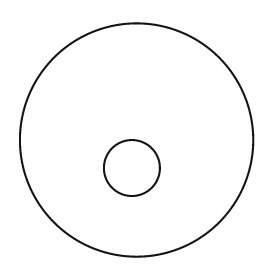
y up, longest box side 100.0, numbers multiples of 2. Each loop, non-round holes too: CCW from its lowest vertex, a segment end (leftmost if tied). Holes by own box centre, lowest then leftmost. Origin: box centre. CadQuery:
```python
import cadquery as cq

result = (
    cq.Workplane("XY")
    .moveTo(0.0, 0.0)
    .circle(50.0)
    .moveTo(-2.0, -12.0)
    .circle(12.0)
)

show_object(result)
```